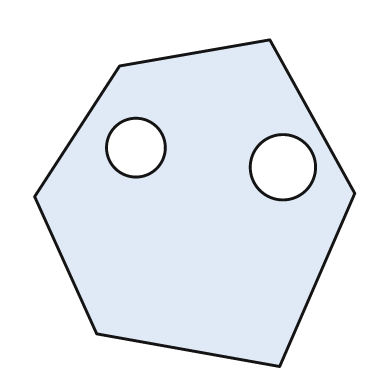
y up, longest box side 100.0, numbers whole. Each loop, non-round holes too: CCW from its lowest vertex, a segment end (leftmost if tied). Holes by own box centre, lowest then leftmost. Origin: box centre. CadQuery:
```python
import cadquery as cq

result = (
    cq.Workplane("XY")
    .moveTo(26.0, -50.0)
    .lineTo(49.0, 3.0)
    .lineTo(23.0, 50.0)
    .lineTo(-23.0, 42.0)
    .lineTo(-49.0, 2.0)
    .lineTo(-30.0, -40.0)
    .close()
    .moveTo(27.0, 11.0)
    .circle(10.0)
    .moveTo(-18.0, 17.0)
    .circle(9.0)
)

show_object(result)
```